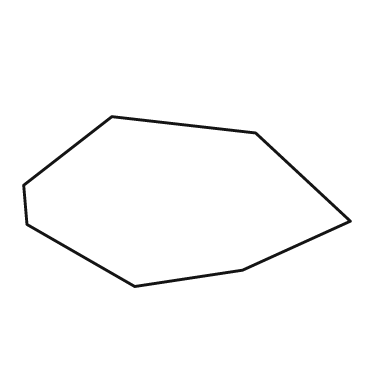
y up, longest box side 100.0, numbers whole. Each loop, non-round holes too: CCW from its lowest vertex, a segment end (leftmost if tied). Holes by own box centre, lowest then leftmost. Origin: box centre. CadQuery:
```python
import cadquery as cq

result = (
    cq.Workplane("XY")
    .moveTo(-16.0, -26.0)
    .lineTo(17.0, -21.0)
    .lineTo(50.0, -6.0)
    .lineTo(21.0, 21.0)
    .lineTo(-23.0, 26.0)
    .lineTo(-50.0, 5.0)
    .lineTo(-49.0, -7.0)
    .close()
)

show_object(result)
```